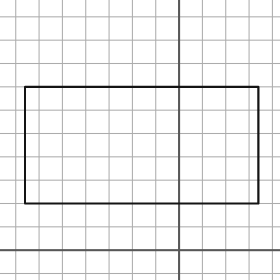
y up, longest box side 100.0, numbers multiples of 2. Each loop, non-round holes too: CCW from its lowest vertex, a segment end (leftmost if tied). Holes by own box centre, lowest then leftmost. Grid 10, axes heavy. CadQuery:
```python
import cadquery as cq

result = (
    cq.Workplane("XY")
    .moveTo(-66.0, 20.0)
    .lineTo(34.0, 20.0)
    .lineTo(34.0, 70.0)
    .lineTo(-66.0, 70.0)
    .close()
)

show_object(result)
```